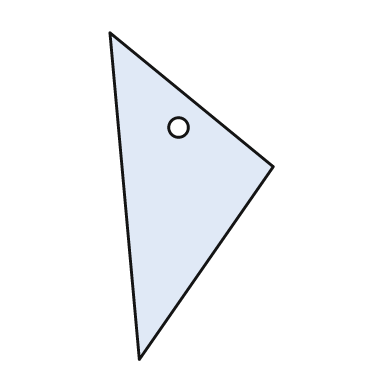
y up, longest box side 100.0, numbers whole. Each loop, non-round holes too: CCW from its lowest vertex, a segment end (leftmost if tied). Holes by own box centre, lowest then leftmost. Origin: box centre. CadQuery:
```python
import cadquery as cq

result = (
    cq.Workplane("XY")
    .moveTo(-16.0, -50.0)
    .lineTo(25.0, 9.0)
    .lineTo(-25.0, 50.0)
    .close()
    .moveTo(-4.0, 21.0)
    .circle(3.0)
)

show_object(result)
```